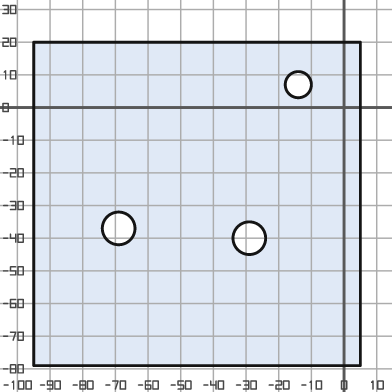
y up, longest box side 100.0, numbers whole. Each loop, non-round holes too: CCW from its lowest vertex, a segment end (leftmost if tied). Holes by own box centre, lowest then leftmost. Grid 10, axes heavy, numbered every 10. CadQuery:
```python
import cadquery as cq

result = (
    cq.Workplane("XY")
    .moveTo(-95.0, -79.0)
    .lineTo(5.0, -79.0)
    .lineTo(5.0, 20.0)
    .lineTo(-95.0, 20.0)
    .close()
    .moveTo(-29.0, -40.0)
    .circle(5.0)
    .moveTo(-69.0, -37.0)
    .circle(5.0)
    .moveTo(-14.0, 7.0)
    .circle(4.0)
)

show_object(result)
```